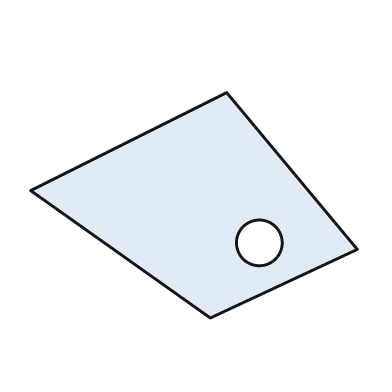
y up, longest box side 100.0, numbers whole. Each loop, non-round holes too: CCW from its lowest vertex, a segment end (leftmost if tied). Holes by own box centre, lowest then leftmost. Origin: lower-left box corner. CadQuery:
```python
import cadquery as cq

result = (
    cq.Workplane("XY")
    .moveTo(55.0, 0.0)
    .lineTo(100.0, 21.0)
    .lineTo(60.0, 69.0)
    .lineTo(0.0, 39.0)
    .close()
    .moveTo(70.0, 23.0)
    .circle(7.0)
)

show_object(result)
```